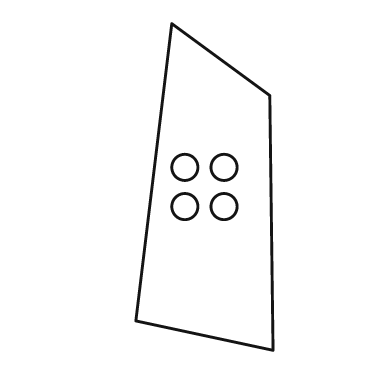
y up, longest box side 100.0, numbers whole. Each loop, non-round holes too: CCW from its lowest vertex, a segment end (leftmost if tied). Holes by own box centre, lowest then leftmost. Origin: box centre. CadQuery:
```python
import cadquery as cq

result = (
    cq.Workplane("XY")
    .moveTo(21.0, -50.0)
    .lineTo(20.0, 28.0)
    .lineTo(-10.0, 50.0)
    .lineTo(-21.0, -41.0)
    .close()
    .moveTo(-6.0, -6.0)
    .circle(4.0)
    .moveTo(6.0, -6.0)
    .circle(4.0)
    .moveTo(-6.0, 6.0)
    .circle(4.0)
    .moveTo(6.0, 6.0)
    .circle(4.0)
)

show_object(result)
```